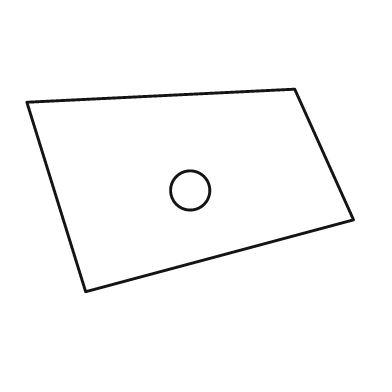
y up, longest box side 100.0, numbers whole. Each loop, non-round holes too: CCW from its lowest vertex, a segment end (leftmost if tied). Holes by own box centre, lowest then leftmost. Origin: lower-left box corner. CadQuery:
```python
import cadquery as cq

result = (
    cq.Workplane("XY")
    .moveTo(18.0, 0.0)
    .lineTo(100.0, 22.0)
    .lineTo(82.0, 62.0)
    .lineTo(0.0, 58.0)
    .close()
    .moveTo(50.0, 31.0)
    .circle(6.0)
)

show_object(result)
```